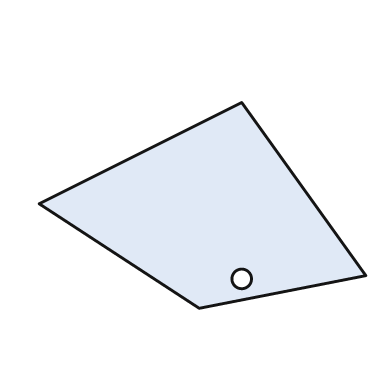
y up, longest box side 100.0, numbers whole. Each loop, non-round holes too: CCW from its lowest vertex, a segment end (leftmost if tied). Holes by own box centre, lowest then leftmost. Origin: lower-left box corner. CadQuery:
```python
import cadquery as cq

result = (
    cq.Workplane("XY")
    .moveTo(49.0, 0.0)
    .lineTo(100.0, 10.0)
    .lineTo(62.0, 63.0)
    .lineTo(0.0, 32.0)
    .close()
    .moveTo(62.0, 9.0)
    .circle(3.0)
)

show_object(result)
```